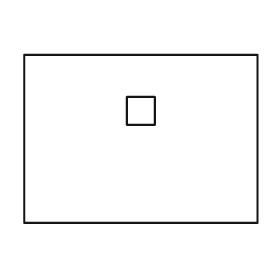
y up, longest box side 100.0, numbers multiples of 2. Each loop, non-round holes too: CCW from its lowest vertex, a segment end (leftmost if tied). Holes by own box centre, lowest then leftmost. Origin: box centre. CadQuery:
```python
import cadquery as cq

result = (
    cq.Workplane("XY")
    .moveTo(-50.0, -36.0)
    .lineTo(50.0, -36.0)
    .lineTo(50.0, 36.0)
    .lineTo(-50.0, 36.0)
    .close()
    .moveTo(-6.0, 6.0)
    .lineTo(6.0, 6.0)
    .lineTo(6.0, 18.0)
    .lineTo(-6.0, 18.0)
    .close()
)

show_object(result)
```